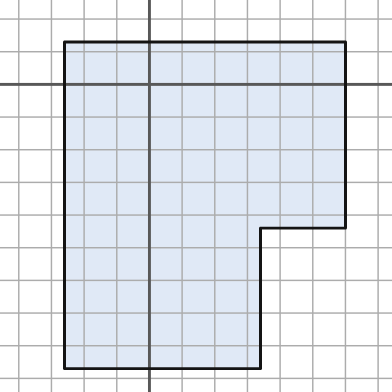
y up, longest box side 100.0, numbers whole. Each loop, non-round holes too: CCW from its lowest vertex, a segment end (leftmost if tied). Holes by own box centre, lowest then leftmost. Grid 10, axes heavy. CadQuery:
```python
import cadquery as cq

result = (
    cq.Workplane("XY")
    .moveTo(-26.0, -87.0)
    .lineTo(34.0, -87.0)
    .lineTo(34.0, -44.0)
    .lineTo(60.0, -44.0)
    .lineTo(60.0, 13.0)
    .lineTo(-26.0, 13.0)
    .close()
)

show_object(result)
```